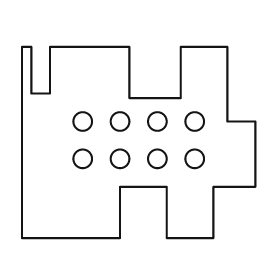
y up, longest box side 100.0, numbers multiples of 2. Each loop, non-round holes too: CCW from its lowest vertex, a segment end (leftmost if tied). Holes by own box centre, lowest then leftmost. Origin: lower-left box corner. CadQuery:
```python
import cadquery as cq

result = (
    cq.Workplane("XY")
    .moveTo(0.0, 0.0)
    .lineTo(42.0, 0.0)
    .lineTo(42.0, 22.0)
    .lineTo(62.0, 22.0)
    .lineTo(62.0, 0.0)
    .lineTo(82.0, 0.0)
    .lineTo(82.0, 22.0)
    .lineTo(100.0, 22.0)
    .lineTo(100.0, 50.0)
    .lineTo(88.0, 50.0)
    .lineTo(88.0, 82.0)
    .lineTo(68.0, 82.0)
    .lineTo(68.0, 60.0)
    .lineTo(46.0, 60.0)
    .lineTo(46.0, 82.0)
    .lineTo(12.0, 82.0)
    .lineTo(12.0, 62.0)
    .lineTo(4.0, 62.0)
    .lineTo(4.0, 82.0)
    .lineTo(0.0, 82.0)
    .close()
    .moveTo(26.0, 34.0)
    .circle(4.0)
    .moveTo(42.0, 34.0)
    .circle(4.0)
    .moveTo(58.0, 34.0)
    .circle(4.0)
    .moveTo(74.0, 34.0)
    .circle(4.0)
    .moveTo(26.0, 50.0)
    .circle(4.0)
    .moveTo(42.0, 50.0)
    .circle(4.0)
    .moveTo(58.0, 50.0)
    .circle(4.0)
    .moveTo(74.0, 50.0)
    .circle(4.0)
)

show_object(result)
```